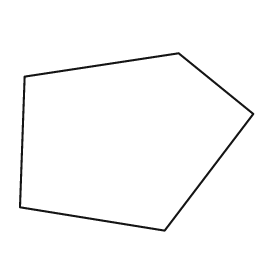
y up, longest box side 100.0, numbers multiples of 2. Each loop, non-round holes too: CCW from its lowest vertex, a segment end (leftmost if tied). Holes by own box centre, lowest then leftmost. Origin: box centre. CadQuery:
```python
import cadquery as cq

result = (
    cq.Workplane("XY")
    .moveTo(12.0, -38.0)
    .lineTo(50.0, 12.0)
    .lineTo(18.0, 38.0)
    .lineTo(-48.0, 28.0)
    .lineTo(-50.0, -28.0)
    .close()
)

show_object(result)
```